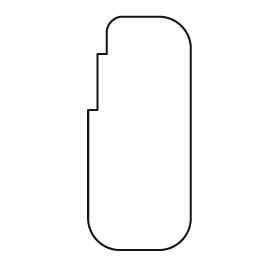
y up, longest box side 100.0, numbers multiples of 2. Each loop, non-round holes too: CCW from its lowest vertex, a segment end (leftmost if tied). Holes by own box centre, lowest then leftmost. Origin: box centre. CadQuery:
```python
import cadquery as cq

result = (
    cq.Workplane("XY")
    .moveTo(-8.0, -50.0)
    .lineTo(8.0, -50.0)
    .threePointArc((18.0, -46.0), (22.0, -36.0))
    .lineTo(22.0, 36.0)
    .threePointArc((18.0, 46.0), (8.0, 50.0))
    .lineTo(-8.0, 50.0)
    .threePointArc((-12.0, 48.0), (-14.0, 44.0))
    .lineTo(-14.0, 34.0)
    .lineTo(-18.0, 34.0)
    .lineTo(-18.0, 10.0)
    .lineTo(-22.0, 10.0)
    .lineTo(-22.0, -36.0)
    .threePointArc((-18.0, -46.0), (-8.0, -50.0))
    .close()
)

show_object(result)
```